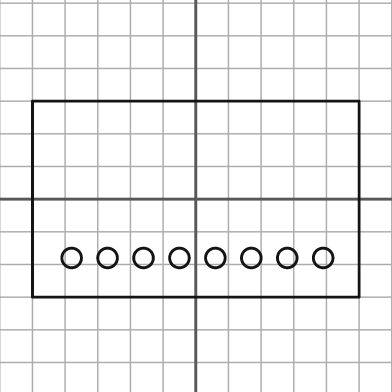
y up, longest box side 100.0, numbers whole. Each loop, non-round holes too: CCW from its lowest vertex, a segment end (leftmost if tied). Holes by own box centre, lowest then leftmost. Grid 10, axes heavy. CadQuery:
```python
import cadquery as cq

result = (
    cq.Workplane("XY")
    .moveTo(-50.0, -30.0)
    .lineTo(50.0, -30.0)
    .lineTo(50.0, 30.0)
    .lineTo(-50.0, 30.0)
    .close()
    .moveTo(-38.0, -18.0)
    .circle(3.0)
    .moveTo(-27.0, -18.0)
    .circle(3.0)
    .moveTo(-16.0, -18.0)
    .circle(3.0)
    .moveTo(-5.0, -18.0)
    .circle(3.0)
    .moveTo(6.0, -18.0)
    .circle(3.0)
    .moveTo(17.0, -18.0)
    .circle(3.0)
    .moveTo(28.0, -18.0)
    .circle(3.0)
    .moveTo(39.0, -18.0)
    .circle(3.0)
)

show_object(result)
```